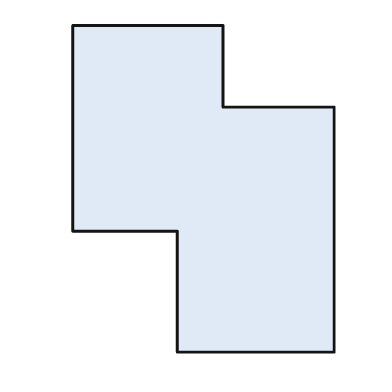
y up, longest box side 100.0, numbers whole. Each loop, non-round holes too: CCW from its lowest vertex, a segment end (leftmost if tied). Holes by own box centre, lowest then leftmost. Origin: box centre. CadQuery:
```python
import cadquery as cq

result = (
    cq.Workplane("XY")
    .moveTo(-8.0, -50.0)
    .lineTo(40.0, -50.0)
    .lineTo(40.0, 25.0)
    .lineTo(6.0, 25.0)
    .lineTo(6.0, 50.0)
    .lineTo(-40.0, 50.0)
    .lineTo(-40.0, -13.0)
    .lineTo(-8.0, -13.0)
    .close()
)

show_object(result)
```